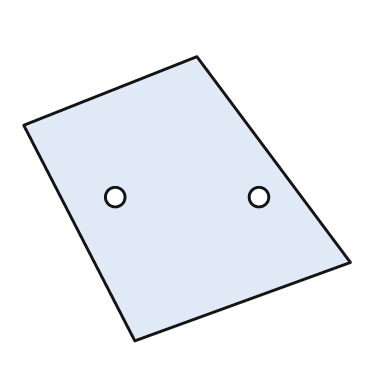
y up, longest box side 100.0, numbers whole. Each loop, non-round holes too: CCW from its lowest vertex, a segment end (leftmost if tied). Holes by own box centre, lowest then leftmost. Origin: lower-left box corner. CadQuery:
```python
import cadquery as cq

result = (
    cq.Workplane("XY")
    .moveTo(34.0, 0.0)
    .lineTo(100.0, 24.0)
    .lineTo(53.0, 87.0)
    .lineTo(0.0, 66.0)
    .close()
    .moveTo(28.0, 44.0)
    .circle(3.0)
    .moveTo(72.0, 44.0)
    .circle(3.0)
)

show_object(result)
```